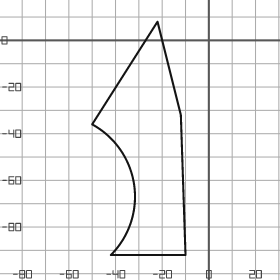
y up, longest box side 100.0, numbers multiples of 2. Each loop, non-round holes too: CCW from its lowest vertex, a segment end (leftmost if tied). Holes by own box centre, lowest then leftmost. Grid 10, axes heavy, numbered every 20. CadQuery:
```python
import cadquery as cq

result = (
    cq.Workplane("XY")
    .moveTo(-42.0, -92.0)
    .lineTo(-10.0, -92.0)
    .lineTo(-12.0, -32.0)
    .lineTo(-22.0, 8.0)
    .lineTo(-50.0, -36.0)
    .threePointArc((-32.0, -62.0), (-42.0, -92.0))
    .close()
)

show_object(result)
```